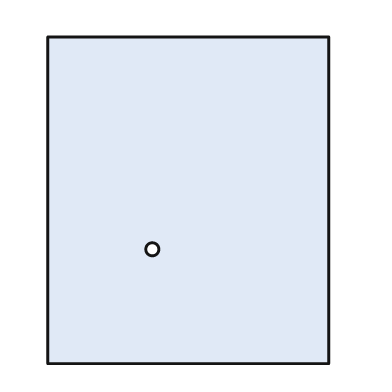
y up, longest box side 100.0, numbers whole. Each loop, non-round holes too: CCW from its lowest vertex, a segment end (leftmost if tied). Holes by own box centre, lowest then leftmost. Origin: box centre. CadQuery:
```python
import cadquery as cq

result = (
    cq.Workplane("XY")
    .moveTo(-43.0, -50.0)
    .lineTo(43.0, -50.0)
    .lineTo(43.0, 50.0)
    .lineTo(-43.0, 50.0)
    .close()
    .moveTo(-11.0, -15.0)
    .circle(2.0)
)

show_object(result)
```